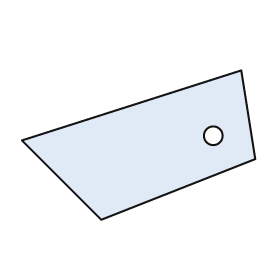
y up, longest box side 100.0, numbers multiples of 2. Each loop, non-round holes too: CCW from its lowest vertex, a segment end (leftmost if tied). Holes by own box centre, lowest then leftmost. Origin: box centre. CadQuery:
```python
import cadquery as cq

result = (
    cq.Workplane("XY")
    .moveTo(-16.0, -32.0)
    .lineTo(50.0, -6.0)
    .lineTo(44.0, 32.0)
    .lineTo(-50.0, 2.0)
    .close()
    .moveTo(32.0, 4.0)
    .circle(4.0)
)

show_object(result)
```